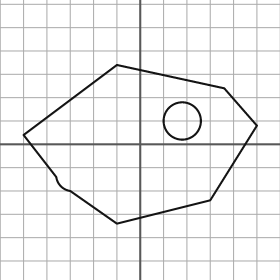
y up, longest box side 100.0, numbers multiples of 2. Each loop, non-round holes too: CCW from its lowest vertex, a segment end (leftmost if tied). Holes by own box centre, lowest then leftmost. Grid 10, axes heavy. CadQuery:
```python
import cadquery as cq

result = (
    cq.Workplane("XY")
    .moveTo(-10.0, -34.0)
    .lineTo(30.0, -24.0)
    .lineTo(50.0, 8.0)
    .lineTo(36.0, 24.0)
    .lineTo(-10.0, 34.0)
    .lineTo(-50.0, 4.0)
    .lineTo(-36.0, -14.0)
    .threePointArc((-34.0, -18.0), (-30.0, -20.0))
    .close()
    .moveTo(18.0, 10.0)
    .circle(8.0)
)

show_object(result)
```